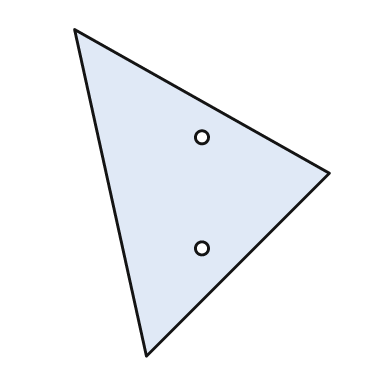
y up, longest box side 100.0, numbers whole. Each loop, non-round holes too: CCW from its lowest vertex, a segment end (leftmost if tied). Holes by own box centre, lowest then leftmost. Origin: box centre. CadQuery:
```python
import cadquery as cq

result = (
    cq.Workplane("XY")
    .moveTo(-17.0, -50.0)
    .lineTo(39.0, 6.0)
    .lineTo(-39.0, 50.0)
    .close()
    .moveTo(0.0, -17.0)
    .circle(2.0)
    .moveTo(0.0, 17.0)
    .circle(2.0)
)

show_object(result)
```